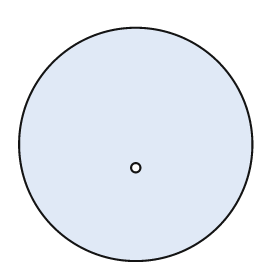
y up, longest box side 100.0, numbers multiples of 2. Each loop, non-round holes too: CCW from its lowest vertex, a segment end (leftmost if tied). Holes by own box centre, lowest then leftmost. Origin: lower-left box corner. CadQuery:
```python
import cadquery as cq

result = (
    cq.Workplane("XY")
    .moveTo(50.0, 50.0)
    .circle(50.0)
    .moveTo(50.0, 40.0)
    .circle(2.0)
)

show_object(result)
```